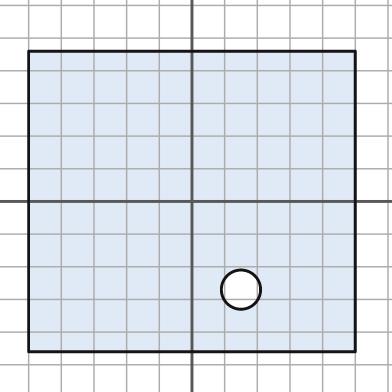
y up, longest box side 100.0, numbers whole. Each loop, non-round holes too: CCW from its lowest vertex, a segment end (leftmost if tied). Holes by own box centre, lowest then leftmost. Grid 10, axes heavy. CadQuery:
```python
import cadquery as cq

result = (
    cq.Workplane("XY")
    .moveTo(-50.0, -46.0)
    .lineTo(50.0, -46.0)
    .lineTo(50.0, 46.0)
    .lineTo(-50.0, 46.0)
    .close()
    .moveTo(15.0, -27.0)
    .circle(6.0)
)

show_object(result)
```